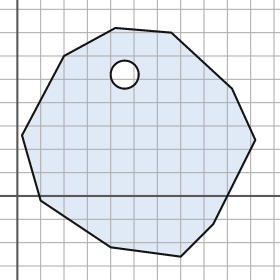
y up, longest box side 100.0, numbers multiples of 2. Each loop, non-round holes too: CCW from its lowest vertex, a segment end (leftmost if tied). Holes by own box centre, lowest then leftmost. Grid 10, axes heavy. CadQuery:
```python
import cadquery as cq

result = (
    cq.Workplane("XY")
    .moveTo(70.0, -26.0)
    .lineTo(84.0, -12.0)
    .lineTo(102.0, 24.0)
    .lineTo(92.0, 46.0)
    .lineTo(66.0, 70.0)
    .lineTo(42.0, 72.0)
    .lineTo(20.0, 60.0)
    .lineTo(2.0, 26.0)
    .lineTo(10.0, -2.0)
    .lineTo(40.0, -22.0)
    .close()
    .moveTo(46.0, 52.0)
    .circle(6.0)
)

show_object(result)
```